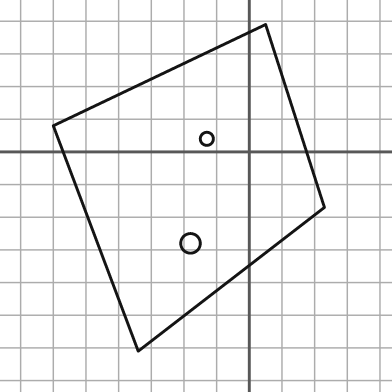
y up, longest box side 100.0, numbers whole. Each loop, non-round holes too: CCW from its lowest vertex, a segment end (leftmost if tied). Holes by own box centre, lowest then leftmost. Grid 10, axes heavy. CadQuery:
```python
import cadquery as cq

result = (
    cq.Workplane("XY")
    .moveTo(-34.0, -61.0)
    .lineTo(23.0, -17.0)
    .lineTo(5.0, 39.0)
    .lineTo(-60.0, 8.0)
    .close()
    .moveTo(-18.0, -28.0)
    .circle(3.0)
    .moveTo(-13.0, 4.0)
    .circle(2.0)
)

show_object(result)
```